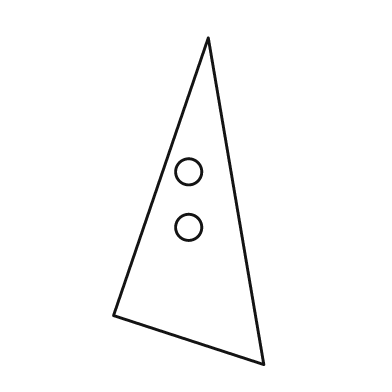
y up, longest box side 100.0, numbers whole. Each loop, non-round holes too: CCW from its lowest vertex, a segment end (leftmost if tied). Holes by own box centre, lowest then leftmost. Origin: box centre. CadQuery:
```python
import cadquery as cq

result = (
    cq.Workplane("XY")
    .moveTo(23.0, -50.0)
    .lineTo(6.0, 50.0)
    .lineTo(-23.0, -35.0)
    .close()
    .moveTo(0.0, -8.0)
    .circle(4.0)
    .moveTo(0.0, 9.0)
    .circle(4.0)
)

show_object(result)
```